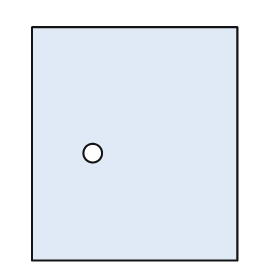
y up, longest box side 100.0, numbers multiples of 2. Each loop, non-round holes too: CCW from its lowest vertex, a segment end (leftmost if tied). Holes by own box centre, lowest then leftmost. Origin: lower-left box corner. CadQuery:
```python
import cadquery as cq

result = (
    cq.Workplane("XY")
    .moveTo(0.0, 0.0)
    .lineTo(88.0, 0.0)
    .lineTo(88.0, 100.0)
    .lineTo(0.0, 100.0)
    .close()
    .moveTo(26.0, 46.0)
    .circle(4.0)
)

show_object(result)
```